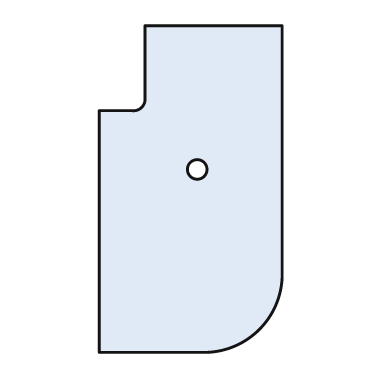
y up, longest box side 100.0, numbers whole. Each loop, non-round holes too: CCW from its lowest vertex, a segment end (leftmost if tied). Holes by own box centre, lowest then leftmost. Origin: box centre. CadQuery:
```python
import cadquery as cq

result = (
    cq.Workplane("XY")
    .moveTo(-28.0, -50.0)
    .lineTo(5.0, -50.0)
    .threePointArc((21.0, -43.0), (28.0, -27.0))
    .lineTo(28.0, 50.0)
    .lineTo(-14.0, 50.0)
    .lineTo(-14.0, 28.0)
    .threePointArc((-15.0, 25.0), (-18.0, 24.0))
    .lineTo(-28.0, 24.0)
    .close()
    .moveTo(2.0, 6.0)
    .circle(3.0)
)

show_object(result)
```